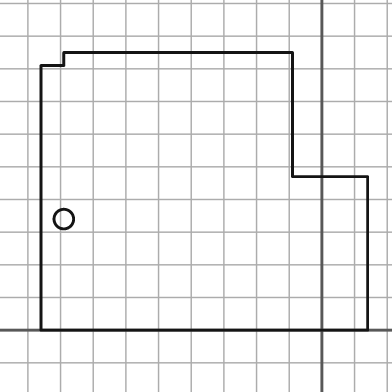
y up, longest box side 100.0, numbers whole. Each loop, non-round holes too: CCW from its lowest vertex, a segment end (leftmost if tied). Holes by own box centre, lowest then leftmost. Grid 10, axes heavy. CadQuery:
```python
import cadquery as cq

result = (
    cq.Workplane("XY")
    .moveTo(-86.0, 0.0)
    .lineTo(14.0, 0.0)
    .lineTo(14.0, 47.0)
    .lineTo(-9.0, 47.0)
    .lineTo(-9.0, 85.0)
    .lineTo(-79.0, 85.0)
    .lineTo(-79.0, 81.0)
    .lineTo(-86.0, 81.0)
    .close()
    .moveTo(-79.0, 34.0)
    .circle(3.0)
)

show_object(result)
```